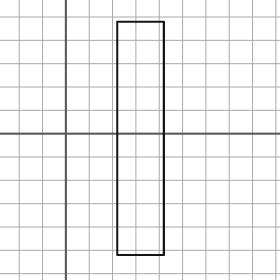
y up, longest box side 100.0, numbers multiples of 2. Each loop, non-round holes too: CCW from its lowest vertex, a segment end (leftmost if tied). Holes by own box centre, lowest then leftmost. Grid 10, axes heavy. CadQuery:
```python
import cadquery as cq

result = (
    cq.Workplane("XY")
    .moveTo(22.0, -52.0)
    .lineTo(42.0, -52.0)
    .lineTo(42.0, 48.0)
    .lineTo(22.0, 48.0)
    .close()
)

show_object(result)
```